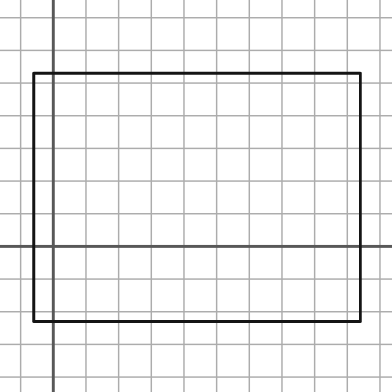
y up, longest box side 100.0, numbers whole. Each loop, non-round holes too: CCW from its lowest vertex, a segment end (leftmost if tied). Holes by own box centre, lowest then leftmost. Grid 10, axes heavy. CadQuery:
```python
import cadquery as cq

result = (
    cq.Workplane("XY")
    .moveTo(-6.0, -23.0)
    .lineTo(94.0, -23.0)
    .lineTo(94.0, 53.0)
    .lineTo(-6.0, 53.0)
    .close()
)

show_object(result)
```